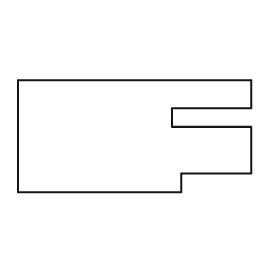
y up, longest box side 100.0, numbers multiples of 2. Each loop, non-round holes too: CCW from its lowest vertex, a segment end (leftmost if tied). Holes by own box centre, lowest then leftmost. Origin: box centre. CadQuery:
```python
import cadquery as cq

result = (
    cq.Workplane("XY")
    .moveTo(-50.0, -24.0)
    .lineTo(20.0, -24.0)
    .lineTo(20.0, -16.0)
    .lineTo(50.0, -16.0)
    .lineTo(50.0, 4.0)
    .lineTo(16.0, 4.0)
    .lineTo(16.0, 12.0)
    .lineTo(50.0, 12.0)
    .lineTo(50.0, 24.0)
    .lineTo(-50.0, 24.0)
    .close()
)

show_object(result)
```